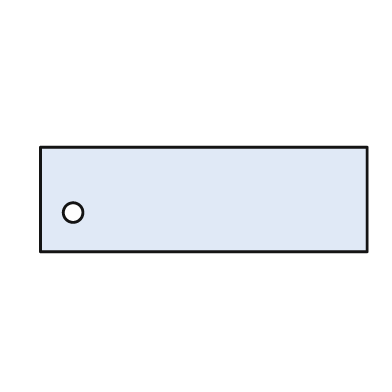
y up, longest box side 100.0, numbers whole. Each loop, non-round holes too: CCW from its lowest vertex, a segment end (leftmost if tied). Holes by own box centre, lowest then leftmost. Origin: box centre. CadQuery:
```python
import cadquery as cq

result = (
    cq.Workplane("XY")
    .moveTo(-50.0, -16.0)
    .lineTo(50.0, -16.0)
    .lineTo(50.0, 16.0)
    .lineTo(-50.0, 16.0)
    .close()
    .moveTo(-40.0, -4.0)
    .circle(3.0)
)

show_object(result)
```